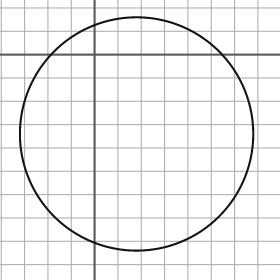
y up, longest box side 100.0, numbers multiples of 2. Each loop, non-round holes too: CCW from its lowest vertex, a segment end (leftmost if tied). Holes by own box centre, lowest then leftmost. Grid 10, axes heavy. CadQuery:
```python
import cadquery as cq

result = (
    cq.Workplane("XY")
    .moveTo(18.0, -34.0)
    .circle(50.0)
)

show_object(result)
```